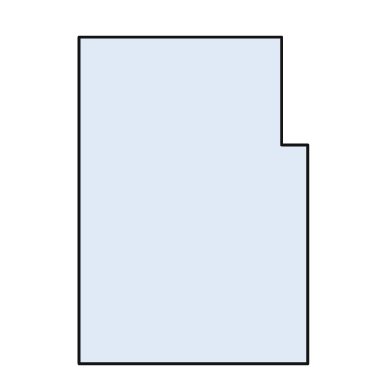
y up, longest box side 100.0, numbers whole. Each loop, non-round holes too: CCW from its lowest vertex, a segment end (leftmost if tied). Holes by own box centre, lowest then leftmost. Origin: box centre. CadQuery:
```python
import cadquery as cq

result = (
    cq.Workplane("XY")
    .moveTo(-35.0, -50.0)
    .lineTo(35.0, -50.0)
    .lineTo(35.0, 17.0)
    .lineTo(27.0, 17.0)
    .lineTo(27.0, 50.0)
    .lineTo(-35.0, 50.0)
    .close()
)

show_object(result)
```